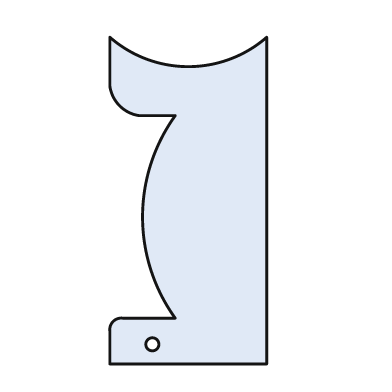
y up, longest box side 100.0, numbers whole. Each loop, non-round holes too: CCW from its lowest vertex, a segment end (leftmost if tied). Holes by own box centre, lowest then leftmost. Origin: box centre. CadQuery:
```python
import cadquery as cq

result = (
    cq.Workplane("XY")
    .moveTo(-24.0, -50.0)
    .lineTo(24.0, -50.0)
    .lineTo(24.0, 50.0)
    .threePointArc((0.0, 41.0), (-24.0, 50.0))
    .lineTo(-24.0, 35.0)
    .threePointArc((-21.0, 29.0), (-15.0, 26.0))
    .lineTo(-4.0, 26.0)
    .threePointArc((-14.0, -5.0), (-4.0, -36.0))
    .lineTo(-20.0, -36.0)
    .threePointArc((-23.0, -37.0), (-24.0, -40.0))
    .close()
    .moveTo(-11.0, -44.0)
    .circle(2.0)
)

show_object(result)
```